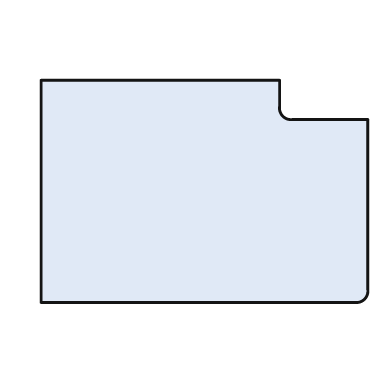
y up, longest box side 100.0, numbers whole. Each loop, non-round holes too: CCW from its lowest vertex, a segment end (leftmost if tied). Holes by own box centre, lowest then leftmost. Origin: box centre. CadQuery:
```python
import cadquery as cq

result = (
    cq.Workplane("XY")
    .moveTo(-50.0, -34.0)
    .lineTo(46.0, -34.0)
    .threePointArc((49.0, -33.0), (50.0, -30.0))
    .lineTo(50.0, 22.0)
    .lineTo(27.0, 22.0)
    .threePointArc((24.0, 23.0), (23.0, 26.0))
    .lineTo(23.0, 34.0)
    .lineTo(-50.0, 34.0)
    .close()
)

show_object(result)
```